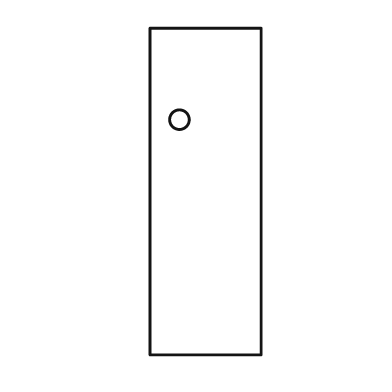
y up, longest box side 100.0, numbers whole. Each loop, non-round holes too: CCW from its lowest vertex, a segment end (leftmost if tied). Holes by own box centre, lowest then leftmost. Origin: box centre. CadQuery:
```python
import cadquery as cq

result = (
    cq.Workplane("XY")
    .moveTo(-17.0, -50.0)
    .lineTo(17.0, -50.0)
    .lineTo(17.0, 50.0)
    .lineTo(-17.0, 50.0)
    .close()
    .moveTo(-8.0, 22.0)
    .circle(3.0)
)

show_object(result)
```